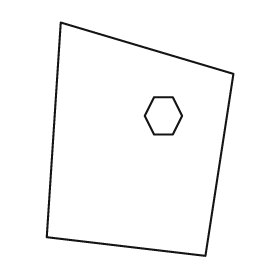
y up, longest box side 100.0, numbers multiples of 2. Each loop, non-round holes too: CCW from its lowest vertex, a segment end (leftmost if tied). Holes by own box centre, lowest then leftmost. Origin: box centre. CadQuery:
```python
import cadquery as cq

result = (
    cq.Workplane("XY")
    .moveTo(28.0, -50.0)
    .lineTo(40.0, 28.0)
    .lineTo(-34.0, 50.0)
    .lineTo(-40.0, -42.0)
    .close()
    .moveTo(6.0, 2.0)
    .lineTo(14.0, 2.0)
    .lineTo(18.0, 10.0)
    .lineTo(14.0, 18.0)
    .lineTo(6.0, 18.0)
    .lineTo(2.0, 10.0)
    .close()
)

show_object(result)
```